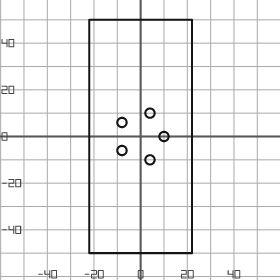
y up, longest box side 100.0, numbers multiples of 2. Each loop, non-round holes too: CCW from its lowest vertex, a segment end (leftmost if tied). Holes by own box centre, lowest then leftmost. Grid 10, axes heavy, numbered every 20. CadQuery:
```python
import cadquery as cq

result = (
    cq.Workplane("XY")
    .moveTo(-22.0, -50.0)
    .lineTo(22.0, -50.0)
    .lineTo(22.0, 50.0)
    .lineTo(-22.0, 50.0)
    .close()
    .moveTo(4.0, -10.0)
    .circle(2.0)
    .moveTo(-8.0, -6.0)
    .circle(2.0)
    .moveTo(10.0, 0.0)
    .circle(2.0)
    .moveTo(-8.0, 6.0)
    .circle(2.0)
    .moveTo(4.0, 10.0)
    .circle(2.0)
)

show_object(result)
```